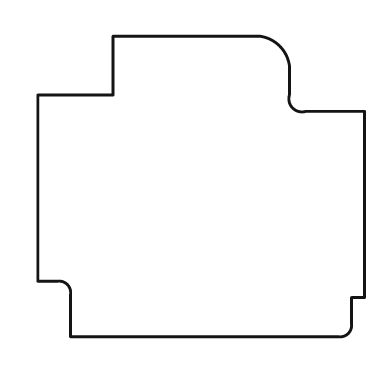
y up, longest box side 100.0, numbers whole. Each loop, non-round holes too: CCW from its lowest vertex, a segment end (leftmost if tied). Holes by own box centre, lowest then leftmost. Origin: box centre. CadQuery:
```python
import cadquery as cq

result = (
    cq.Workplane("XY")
    .moveTo(-40.0, -46.0)
    .lineTo(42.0, -46.0)
    .threePointArc((45.0, -45.0), (46.0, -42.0))
    .lineTo(46.0, -34.0)
    .lineTo(50.0, -34.0)
    .lineTo(50.0, 23.0)
    .lineTo(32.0, 23.0)
    .threePointArc((28.0, 24.0), (27.0, 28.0))
    .lineTo(27.0, 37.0)
    .threePointArc((24.0, 43.0), (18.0, 46.0))
    .lineTo(-27.0, 46.0)
    .lineTo(-27.0, 28.0)
    .lineTo(-50.0, 28.0)
    .lineTo(-50.0, -29.0)
    .lineTo(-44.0, -29.0)
    .threePointArc((-41.0, -30.0), (-40.0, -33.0))
    .close()
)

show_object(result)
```